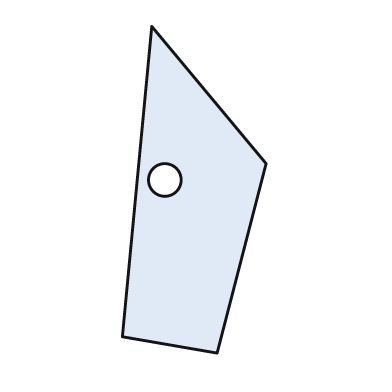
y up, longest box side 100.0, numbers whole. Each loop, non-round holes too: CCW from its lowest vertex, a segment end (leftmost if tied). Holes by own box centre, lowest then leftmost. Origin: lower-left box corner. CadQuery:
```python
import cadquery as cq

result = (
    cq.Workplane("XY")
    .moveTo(29.0, 0.0)
    .lineTo(44.0, 58.0)
    .lineTo(9.0, 100.0)
    .lineTo(0.0, 5.0)
    .close()
    .moveTo(13.0, 53.0)
    .circle(5.0)
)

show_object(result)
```